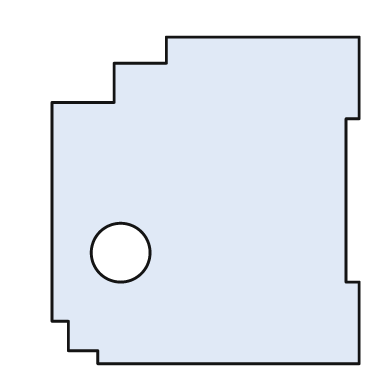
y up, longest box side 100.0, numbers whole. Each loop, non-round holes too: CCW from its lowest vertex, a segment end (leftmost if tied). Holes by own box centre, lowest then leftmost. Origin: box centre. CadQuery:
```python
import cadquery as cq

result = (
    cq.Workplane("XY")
    .moveTo(-33.0, -50.0)
    .lineTo(47.0, -50.0)
    .lineTo(47.0, -25.0)
    .lineTo(43.0, -25.0)
    .lineTo(43.0, 25.0)
    .lineTo(47.0, 25.0)
    .lineTo(47.0, 50.0)
    .lineTo(-12.0, 50.0)
    .lineTo(-12.0, 42.0)
    .lineTo(-28.0, 42.0)
    .lineTo(-28.0, 30.0)
    .lineTo(-47.0, 30.0)
    .lineTo(-47.0, -37.0)
    .lineTo(-42.0, -37.0)
    .lineTo(-42.0, -46.0)
    .lineTo(-33.0, -46.0)
    .close()
    .moveTo(-26.0, -16.0)
    .circle(9.0)
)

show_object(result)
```